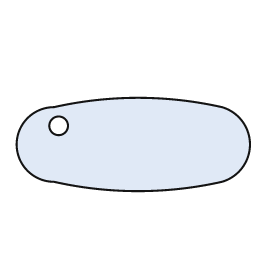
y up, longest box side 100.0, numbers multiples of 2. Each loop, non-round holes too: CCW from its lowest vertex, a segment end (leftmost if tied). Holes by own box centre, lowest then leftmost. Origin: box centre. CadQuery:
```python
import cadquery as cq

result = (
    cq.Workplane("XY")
    .moveTo(-34.0, -16.0)
    .threePointArc((2.0, -20.0), (38.0, -16.0))
    .threePointArc((50.0, 0.0), (38.0, 16.0))
    .threePointArc((2.0, 20.0), (-34.0, 16.0))
    .threePointArc((-50.0, 0.0), (-34.0, -16.0))
    .close()
    .moveTo(-32.0, 8.0)
    .circle(4.0)
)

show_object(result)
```